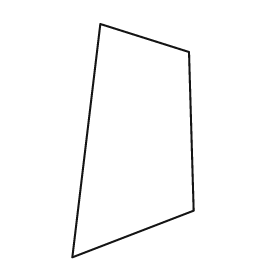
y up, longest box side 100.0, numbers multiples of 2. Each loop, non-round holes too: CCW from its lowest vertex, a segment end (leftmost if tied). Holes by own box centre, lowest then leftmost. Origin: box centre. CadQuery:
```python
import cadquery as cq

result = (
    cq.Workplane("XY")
    .moveTo(-26.0, -50.0)
    .lineTo(26.0, -30.0)
    .lineTo(24.0, 38.0)
    .lineTo(-14.0, 50.0)
    .close()
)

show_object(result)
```